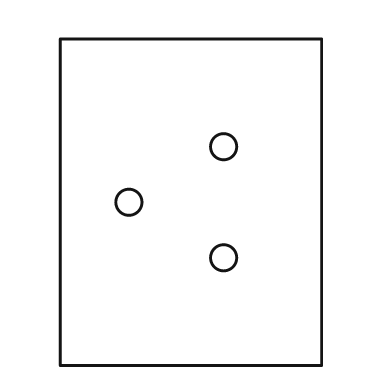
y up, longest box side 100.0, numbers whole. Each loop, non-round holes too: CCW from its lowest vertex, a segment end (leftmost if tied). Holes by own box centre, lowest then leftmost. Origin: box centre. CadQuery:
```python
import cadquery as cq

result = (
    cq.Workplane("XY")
    .moveTo(-40.0, -50.0)
    .lineTo(40.0, -50.0)
    .lineTo(40.0, 50.0)
    .lineTo(-40.0, 50.0)
    .close()
    .moveTo(10.0, -17.0)
    .circle(4.0)
    .moveTo(-19.0, 0.0)
    .circle(4.0)
    .moveTo(10.0, 17.0)
    .circle(4.0)
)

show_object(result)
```